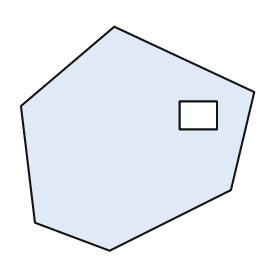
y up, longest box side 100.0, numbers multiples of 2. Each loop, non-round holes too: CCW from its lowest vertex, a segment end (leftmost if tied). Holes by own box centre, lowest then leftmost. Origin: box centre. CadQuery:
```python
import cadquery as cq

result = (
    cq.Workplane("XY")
    .moveTo(-12.0, -48.0)
    .lineTo(40.0, -22.0)
    .lineTo(50.0, 20.0)
    .lineTo(-10.0, 48.0)
    .lineTo(-50.0, 14.0)
    .lineTo(-44.0, -36.0)
    .close()
    .moveTo(18.0, 4.0)
    .lineTo(34.0, 4.0)
    .lineTo(34.0, 16.0)
    .lineTo(18.0, 16.0)
    .close()
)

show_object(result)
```